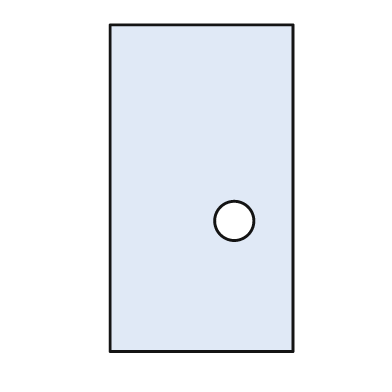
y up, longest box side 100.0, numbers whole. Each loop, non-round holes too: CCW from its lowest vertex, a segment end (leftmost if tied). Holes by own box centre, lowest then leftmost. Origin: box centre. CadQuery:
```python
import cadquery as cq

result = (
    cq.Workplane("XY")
    .moveTo(-28.0, -50.0)
    .lineTo(28.0, -50.0)
    .lineTo(28.0, 50.0)
    .lineTo(-28.0, 50.0)
    .close()
    .moveTo(10.0, -10.0)
    .circle(6.0)
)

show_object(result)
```